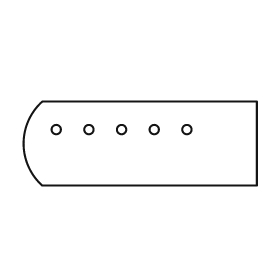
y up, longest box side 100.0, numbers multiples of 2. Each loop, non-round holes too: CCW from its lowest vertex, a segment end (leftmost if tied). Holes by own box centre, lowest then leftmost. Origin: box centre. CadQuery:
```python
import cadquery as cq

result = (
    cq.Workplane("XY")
    .moveTo(-42.0, -18.0)
    .lineTo(50.0, -18.0)
    .lineTo(50.0, 18.0)
    .lineTo(-42.0, 18.0)
    .threePointArc((-50.0, 0.0), (-42.0, -18.0))
    .close()
    .moveTo(-36.0, 6.0)
    .circle(2.0)
    .moveTo(-22.0, 6.0)
    .circle(2.0)
    .moveTo(-8.0, 6.0)
    .circle(2.0)
    .moveTo(6.0, 6.0)
    .circle(2.0)
    .moveTo(20.0, 6.0)
    .circle(2.0)
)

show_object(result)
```